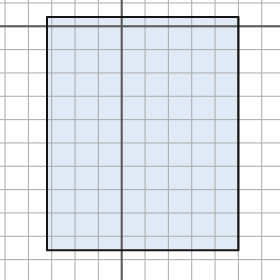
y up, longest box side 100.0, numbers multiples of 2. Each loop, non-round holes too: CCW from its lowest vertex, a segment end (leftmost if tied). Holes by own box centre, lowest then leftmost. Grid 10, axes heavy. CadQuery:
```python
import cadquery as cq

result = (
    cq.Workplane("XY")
    .moveTo(-32.0, -96.0)
    .lineTo(50.0, -96.0)
    .lineTo(50.0, 4.0)
    .lineTo(-32.0, 4.0)
    .close()
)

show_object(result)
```